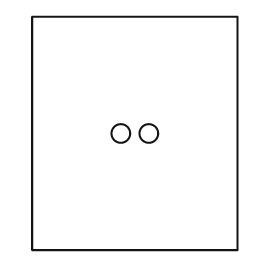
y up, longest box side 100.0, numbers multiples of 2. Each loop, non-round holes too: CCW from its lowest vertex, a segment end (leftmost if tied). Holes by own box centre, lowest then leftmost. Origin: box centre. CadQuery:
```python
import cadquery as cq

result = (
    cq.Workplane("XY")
    .moveTo(-44.0, -50.0)
    .lineTo(44.0, -50.0)
    .lineTo(44.0, 50.0)
    .lineTo(-44.0, 50.0)
    .close()
    .moveTo(-6.0, 0.0)
    .circle(4.0)
    .moveTo(6.0, 0.0)
    .circle(4.0)
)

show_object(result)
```